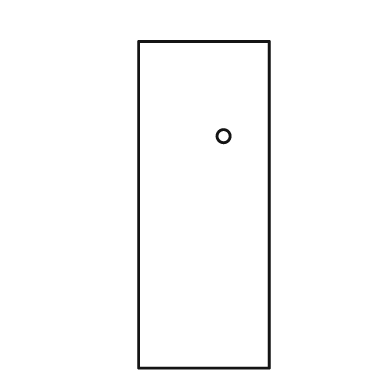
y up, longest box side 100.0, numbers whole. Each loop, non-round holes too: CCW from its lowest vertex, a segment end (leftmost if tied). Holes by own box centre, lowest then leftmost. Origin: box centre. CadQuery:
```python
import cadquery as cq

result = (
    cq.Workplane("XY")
    .moveTo(-20.0, -50.0)
    .lineTo(20.0, -50.0)
    .lineTo(20.0, 50.0)
    .lineTo(-20.0, 50.0)
    .close()
    .moveTo(6.0, 21.0)
    .circle(2.0)
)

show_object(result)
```